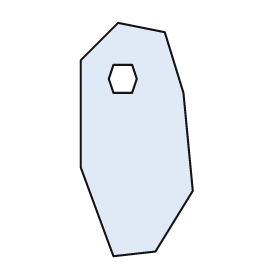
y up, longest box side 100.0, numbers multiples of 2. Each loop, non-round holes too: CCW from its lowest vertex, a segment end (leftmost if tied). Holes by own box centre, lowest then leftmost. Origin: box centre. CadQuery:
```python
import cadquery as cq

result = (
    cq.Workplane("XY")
    .moveTo(-10.0, -50.0)
    .lineTo(8.0, -48.0)
    .lineTo(24.0, -22.0)
    .lineTo(20.0, 20.0)
    .lineTo(12.0, 46.0)
    .lineTo(-8.0, 50.0)
    .lineTo(-24.0, 34.0)
    .lineTo(-24.0, -12.0)
    .close()
    .moveTo(-10.0, 20.0)
    .lineTo(-2.0, 20.0)
    .lineTo(0.0, 26.0)
    .lineTo(-2.0, 32.0)
    .lineTo(-10.0, 32.0)
    .lineTo(-12.0, 26.0)
    .close()
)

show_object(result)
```